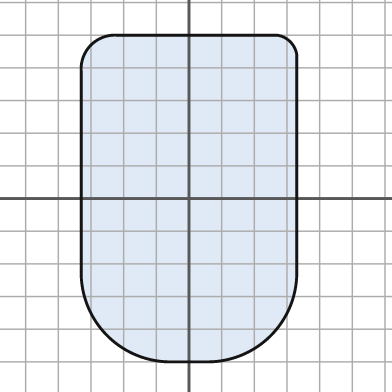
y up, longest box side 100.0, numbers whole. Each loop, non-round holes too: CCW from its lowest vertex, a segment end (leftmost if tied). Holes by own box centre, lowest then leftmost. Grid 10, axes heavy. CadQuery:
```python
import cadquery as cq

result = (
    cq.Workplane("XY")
    .moveTo(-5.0, -50.0)
    .lineTo(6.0, -50.0)
    .threePointArc((25.0, -42.0), (33.0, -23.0))
    .lineTo(33.0, 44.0)
    .threePointArc((31.0, 48.0), (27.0, 50.0))
    .lineTo(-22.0, 50.0)
    .threePointArc((-30.0, 47.0), (-33.0, 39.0))
    .lineTo(-33.0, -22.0)
    .threePointArc((-25.0, -42.0), (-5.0, -50.0))
    .close()
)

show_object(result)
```